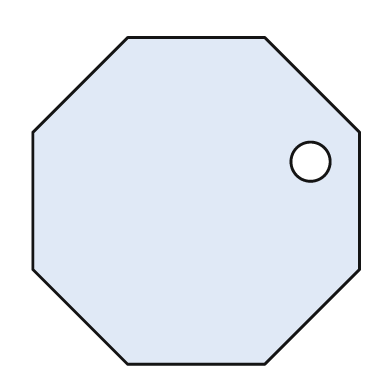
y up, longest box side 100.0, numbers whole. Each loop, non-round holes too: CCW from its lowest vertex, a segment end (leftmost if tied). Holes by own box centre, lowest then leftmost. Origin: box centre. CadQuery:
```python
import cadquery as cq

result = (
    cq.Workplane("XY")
    .moveTo(-21.0, -50.0)
    .lineTo(21.0, -50.0)
    .lineTo(50.0, -21.0)
    .lineTo(50.0, 21.0)
    .lineTo(21.0, 50.0)
    .lineTo(-21.0, 50.0)
    .lineTo(-50.0, 21.0)
    .lineTo(-50.0, -21.0)
    .close()
    .moveTo(35.0, 12.0)
    .circle(6.0)
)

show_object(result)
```